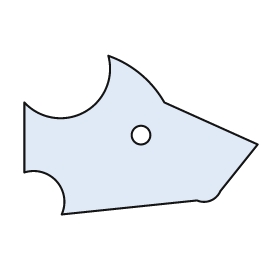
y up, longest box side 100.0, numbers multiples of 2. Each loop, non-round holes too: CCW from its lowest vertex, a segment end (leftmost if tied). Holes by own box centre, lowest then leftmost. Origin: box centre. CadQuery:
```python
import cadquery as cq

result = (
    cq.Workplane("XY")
    .moveTo(-34.0, -34.0)
    .lineTo(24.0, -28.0)
    .threePointArc((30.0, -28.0), (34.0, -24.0))
    .lineTo(50.0, -4.0)
    .lineTo(10.0, 14.0)
    .threePointArc((0.0, 26.0), (-14.0, 34.0))
    .threePointArc((-24.0, 10.0), (-50.0, 14.0))
    .lineTo(-50.0, -16.0)
    .threePointArc((-36.0, -20.0), (-34.0, -34.0))
    .close()
    .moveTo(0.0, 0.0)
    .circle(4.0)
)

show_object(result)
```